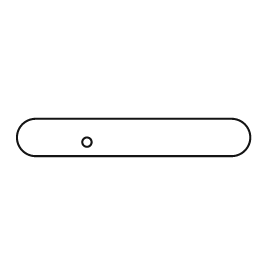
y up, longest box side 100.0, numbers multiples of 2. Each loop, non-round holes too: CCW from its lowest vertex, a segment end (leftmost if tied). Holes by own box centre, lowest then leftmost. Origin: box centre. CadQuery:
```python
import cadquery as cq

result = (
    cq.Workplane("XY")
    .moveTo(-42.0, -8.0)
    .lineTo(42.0, -8.0)
    .threePointArc((50.0, 0.0), (42.0, 8.0))
    .lineTo(-42.0, 8.0)
    .threePointArc((-50.0, 0.0), (-42.0, -8.0))
    .close()
    .moveTo(-20.0, -2.0)
    .circle(2.0)
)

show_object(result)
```